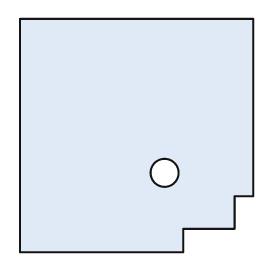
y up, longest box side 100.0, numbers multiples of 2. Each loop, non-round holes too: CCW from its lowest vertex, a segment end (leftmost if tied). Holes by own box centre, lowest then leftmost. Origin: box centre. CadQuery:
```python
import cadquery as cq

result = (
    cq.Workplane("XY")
    .moveTo(-50.0, -50.0)
    .lineTo(20.0, -50.0)
    .lineTo(20.0, -40.0)
    .lineTo(42.0, -40.0)
    .lineTo(42.0, -26.0)
    .lineTo(50.0, -26.0)
    .lineTo(50.0, 50.0)
    .lineTo(-50.0, 50.0)
    .close()
    .moveTo(12.0, -16.0)
    .circle(6.0)
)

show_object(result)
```